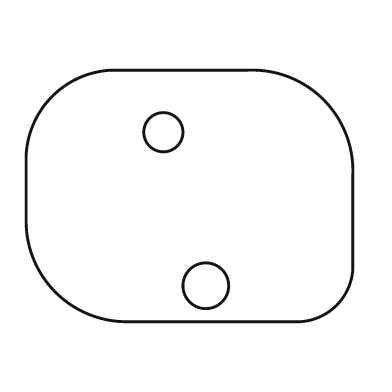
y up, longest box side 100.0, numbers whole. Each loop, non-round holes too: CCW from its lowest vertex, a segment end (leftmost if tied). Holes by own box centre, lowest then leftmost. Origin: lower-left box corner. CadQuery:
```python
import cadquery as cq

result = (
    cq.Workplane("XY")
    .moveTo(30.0, 0.0)
    .lineTo(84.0, 0.0)
    .threePointArc((95.0, 5.0), (100.0, 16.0))
    .lineTo(100.0, 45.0)
    .threePointArc((91.0, 68.0), (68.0, 77.0))
    .lineTo(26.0, 77.0)
    .threePointArc((8.0, 69.0), (0.0, 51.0))
    .lineTo(0.0, 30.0)
    .threePointArc((9.0, 9.0), (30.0, 0.0))
    .close()
    .moveTo(55.0, 11.0)
    .circle(7.0)
    .moveTo(42.0, 58.0)
    .circle(6.0)
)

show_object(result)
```